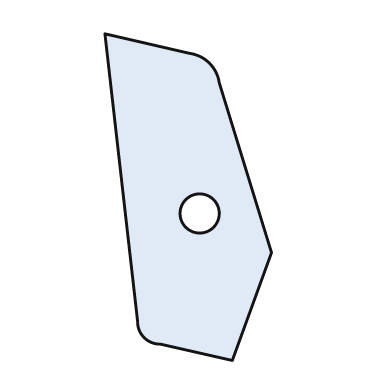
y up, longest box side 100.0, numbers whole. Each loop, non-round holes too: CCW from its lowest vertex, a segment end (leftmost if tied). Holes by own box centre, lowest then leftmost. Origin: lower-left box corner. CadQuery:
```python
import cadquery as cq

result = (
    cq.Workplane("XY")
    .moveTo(39.0, 0.0)
    .lineTo(51.0, 33.0)
    .lineTo(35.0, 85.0)
    .threePointArc((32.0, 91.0), (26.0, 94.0))
    .lineTo(0.0, 100.0)
    .lineTo(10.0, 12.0)
    .threePointArc((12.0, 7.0), (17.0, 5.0))
    .close()
    .moveTo(29.0, 45.0)
    .circle(6.0)
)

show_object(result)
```